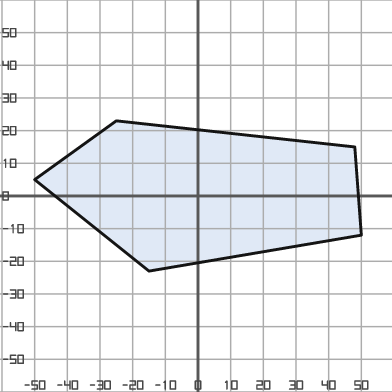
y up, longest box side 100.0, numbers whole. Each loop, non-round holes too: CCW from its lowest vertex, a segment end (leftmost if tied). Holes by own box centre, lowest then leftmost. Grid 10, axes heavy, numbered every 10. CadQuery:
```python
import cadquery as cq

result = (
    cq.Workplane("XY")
    .moveTo(-15.0, -23.0)
    .lineTo(50.0, -12.0)
    .lineTo(48.0, 15.0)
    .lineTo(-25.0, 23.0)
    .lineTo(-50.0, 5.0)
    .close()
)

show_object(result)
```